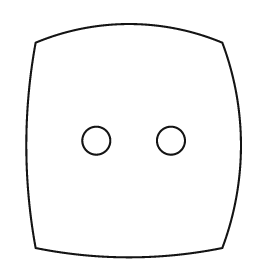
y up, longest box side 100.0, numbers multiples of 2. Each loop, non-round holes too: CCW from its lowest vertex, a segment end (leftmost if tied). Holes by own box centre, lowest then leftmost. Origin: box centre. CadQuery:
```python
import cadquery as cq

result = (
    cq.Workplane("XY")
    .moveTo(-42.0, -46.0)
    .threePointArc((-2.0, -50.0), (38.0, -46.0))
    .threePointArc((46.0, -2.0), (38.0, 42.0))
    .threePointArc((-2.0, 50.0), (-42.0, 42.0))
    .threePointArc((-46.0, -2.0), (-42.0, -46.0))
    .close()
    .moveTo(-16.0, 0.0)
    .circle(6.0)
    .moveTo(16.0, 0.0)
    .circle(6.0)
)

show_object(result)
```